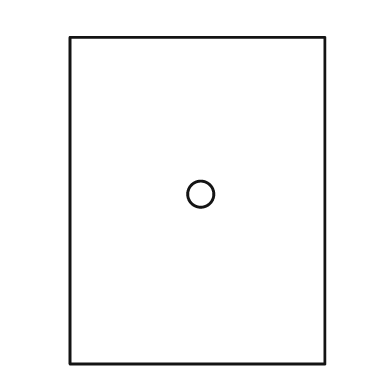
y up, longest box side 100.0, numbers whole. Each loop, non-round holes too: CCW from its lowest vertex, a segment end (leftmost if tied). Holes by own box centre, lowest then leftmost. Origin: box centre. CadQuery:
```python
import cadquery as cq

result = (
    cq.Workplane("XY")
    .moveTo(-39.0, -50.0)
    .lineTo(39.0, -50.0)
    .lineTo(39.0, 50.0)
    .lineTo(-39.0, 50.0)
    .close()
    .moveTo(1.0, 2.0)
    .circle(4.0)
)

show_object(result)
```